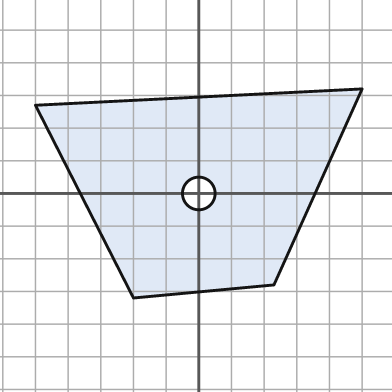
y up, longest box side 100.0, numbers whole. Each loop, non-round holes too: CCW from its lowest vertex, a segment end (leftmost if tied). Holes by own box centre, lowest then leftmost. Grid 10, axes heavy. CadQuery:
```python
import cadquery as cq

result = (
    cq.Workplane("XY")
    .moveTo(-20.0, -32.0)
    .lineTo(23.0, -28.0)
    .lineTo(50.0, 32.0)
    .lineTo(-50.0, 27.0)
    .close()
    .moveTo(0.0, 0.0)
    .circle(5.0)
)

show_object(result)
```